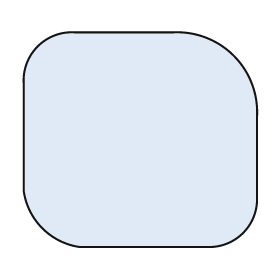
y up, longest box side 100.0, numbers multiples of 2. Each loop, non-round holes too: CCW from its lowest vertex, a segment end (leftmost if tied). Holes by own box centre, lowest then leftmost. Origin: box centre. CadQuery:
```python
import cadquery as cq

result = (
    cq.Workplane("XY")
    .moveTo(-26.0, -46.0)
    .lineTo(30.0, -46.0)
    .threePointArc((44.0, -40.0), (50.0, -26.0))
    .lineTo(50.0, 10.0)
    .threePointArc((40.0, 36.0), (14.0, 46.0))
    .lineTo(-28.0, 46.0)
    .threePointArc((-44.0, 40.0), (-50.0, 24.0))
    .lineTo(-50.0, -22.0)
    .threePointArc((-42.0, -38.0), (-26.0, -46.0))
    .close()
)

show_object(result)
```